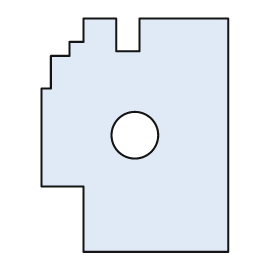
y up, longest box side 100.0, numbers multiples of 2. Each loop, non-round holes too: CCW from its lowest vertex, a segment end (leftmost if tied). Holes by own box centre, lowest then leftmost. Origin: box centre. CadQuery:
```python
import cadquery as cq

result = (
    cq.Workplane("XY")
    .moveTo(-22.0, -50.0)
    .lineTo(40.0, -50.0)
    .lineTo(40.0, 50.0)
    .lineTo(2.0, 50.0)
    .lineTo(2.0, 36.0)
    .lineTo(-8.0, 36.0)
    .lineTo(-8.0, 50.0)
    .lineTo(-22.0, 50.0)
    .lineTo(-22.0, 40.0)
    .lineTo(-28.0, 40.0)
    .lineTo(-28.0, 34.0)
    .lineTo(-36.0, 34.0)
    .lineTo(-36.0, 20.0)
    .lineTo(-40.0, 20.0)
    .lineTo(-40.0, -22.0)
    .lineTo(-22.0, -22.0)
    .close()
    .moveTo(0.0, 0.0)
    .circle(10.0)
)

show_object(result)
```